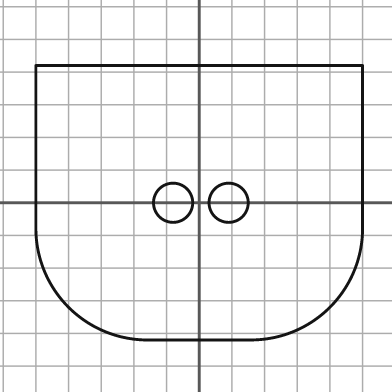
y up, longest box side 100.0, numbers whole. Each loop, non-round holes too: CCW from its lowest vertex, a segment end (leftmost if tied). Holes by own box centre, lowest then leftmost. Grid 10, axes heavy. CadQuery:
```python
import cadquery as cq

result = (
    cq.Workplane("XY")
    .moveTo(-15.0, -42.0)
    .lineTo(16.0, -42.0)
    .threePointArc((40.0, -32.0), (50.0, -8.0))
    .lineTo(50.0, 42.0)
    .lineTo(-50.0, 42.0)
    .lineTo(-50.0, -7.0)
    .threePointArc((-40.0, -32.0), (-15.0, -42.0))
    .close()
    .moveTo(-8.0, 0.0)
    .circle(6.0)
    .moveTo(9.0, 0.0)
    .circle(6.0)
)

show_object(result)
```